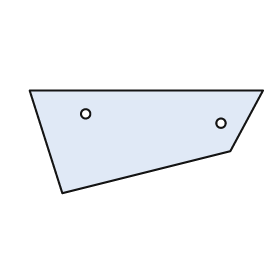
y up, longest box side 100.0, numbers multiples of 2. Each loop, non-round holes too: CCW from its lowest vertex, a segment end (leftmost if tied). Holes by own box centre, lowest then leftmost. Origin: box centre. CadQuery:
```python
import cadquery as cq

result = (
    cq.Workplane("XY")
    .moveTo(-36.0, -22.0)
    .lineTo(36.0, -4.0)
    .lineTo(50.0, 22.0)
    .lineTo(-50.0, 22.0)
    .close()
    .moveTo(32.0, 8.0)
    .circle(2.0)
    .moveTo(-26.0, 12.0)
    .circle(2.0)
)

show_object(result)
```